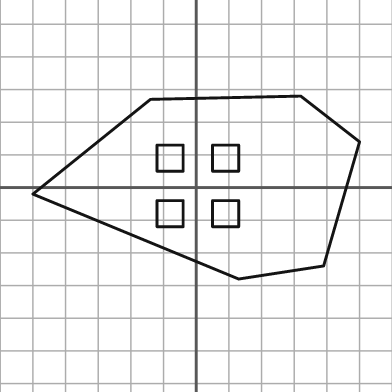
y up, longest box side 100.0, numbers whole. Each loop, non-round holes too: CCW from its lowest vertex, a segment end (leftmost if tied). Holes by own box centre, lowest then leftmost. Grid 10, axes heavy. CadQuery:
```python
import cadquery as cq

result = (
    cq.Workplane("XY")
    .moveTo(13.0, -28.0)
    .lineTo(39.0, -24.0)
    .lineTo(50.0, 14.0)
    .lineTo(32.0, 28.0)
    .lineTo(-14.0, 27.0)
    .lineTo(-50.0, -2.0)
    .close()
    .moveTo(-12.0, -12.0)
    .lineTo(-4.0, -12.0)
    .lineTo(-4.0, -4.0)
    .lineTo(-12.0, -4.0)
    .close()
    .moveTo(5.0, -12.0)
    .lineTo(13.0, -12.0)
    .lineTo(13.0, -4.0)
    .lineTo(5.0, -4.0)
    .close()
    .moveTo(-12.0, 5.0)
    .lineTo(-4.0, 5.0)
    .lineTo(-4.0, 13.0)
    .lineTo(-12.0, 13.0)
    .close()
    .moveTo(5.0, 5.0)
    .lineTo(13.0, 5.0)
    .lineTo(13.0, 13.0)
    .lineTo(5.0, 13.0)
    .close()
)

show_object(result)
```